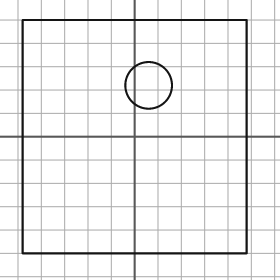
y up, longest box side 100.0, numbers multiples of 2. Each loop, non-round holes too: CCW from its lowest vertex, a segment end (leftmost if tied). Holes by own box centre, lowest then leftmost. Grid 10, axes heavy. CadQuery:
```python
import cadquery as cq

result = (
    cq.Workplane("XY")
    .moveTo(-48.0, -50.0)
    .lineTo(48.0, -50.0)
    .lineTo(48.0, 50.0)
    .lineTo(-48.0, 50.0)
    .close()
    .moveTo(6.0, 22.0)
    .circle(10.0)
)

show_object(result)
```